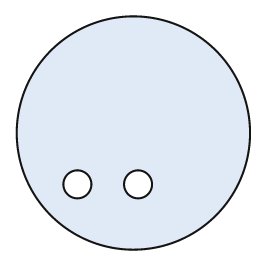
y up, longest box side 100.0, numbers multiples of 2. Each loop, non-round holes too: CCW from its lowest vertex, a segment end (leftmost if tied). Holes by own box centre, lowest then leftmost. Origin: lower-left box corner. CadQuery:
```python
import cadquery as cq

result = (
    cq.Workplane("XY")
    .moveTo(50.0, 50.0)
    .circle(50.0)
    .moveTo(26.0, 28.0)
    .circle(6.0)
    .moveTo(52.0, 28.0)
    .circle(6.0)
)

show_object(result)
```